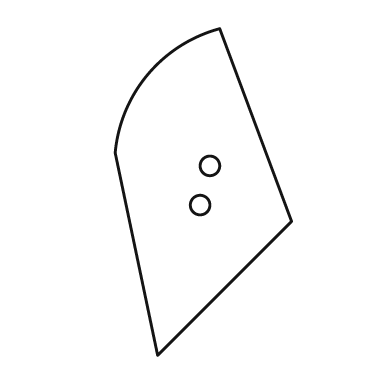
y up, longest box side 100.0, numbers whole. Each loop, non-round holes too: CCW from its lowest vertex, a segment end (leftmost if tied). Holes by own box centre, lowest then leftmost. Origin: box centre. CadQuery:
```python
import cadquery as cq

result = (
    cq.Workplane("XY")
    .moveTo(-14.0, -50.0)
    .lineTo(27.0, -9.0)
    .lineTo(5.0, 50.0)
    .threePointArc((-17.0, 36.0), (-27.0, 12.0))
    .close()
    .moveTo(-1.0, -4.0)
    .circle(3.0)
    .moveTo(2.0, 8.0)
    .circle(3.0)
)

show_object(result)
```